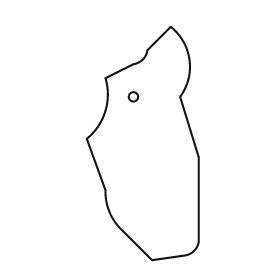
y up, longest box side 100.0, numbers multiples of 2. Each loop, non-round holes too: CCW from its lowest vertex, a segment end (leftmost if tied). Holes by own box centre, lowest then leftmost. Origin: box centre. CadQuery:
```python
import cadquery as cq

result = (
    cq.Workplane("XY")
    .moveTo(4.0, -50.0)
    .lineTo(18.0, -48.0)
    .threePointArc((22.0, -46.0), (24.0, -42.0))
    .lineTo(24.0, -6.0)
    .lineTo(16.0, 20.0)
    .threePointArc((20.0, 36.0), (12.0, 50.0))
    .lineTo(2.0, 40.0)
    .threePointArc((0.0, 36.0), (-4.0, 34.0))
    .lineTo(-16.0, 28.0)
    .threePointArc((-16.0, 14.0), (-24.0, 2.0))
    .lineTo(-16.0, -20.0)
    .threePointArc((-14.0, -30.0), (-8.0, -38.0))
    .close()
    .moveTo(-4.0, 20.0)
    .circle(2.0)
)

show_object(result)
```